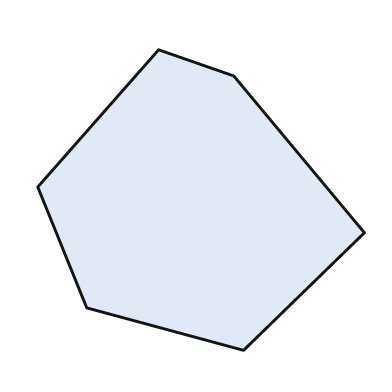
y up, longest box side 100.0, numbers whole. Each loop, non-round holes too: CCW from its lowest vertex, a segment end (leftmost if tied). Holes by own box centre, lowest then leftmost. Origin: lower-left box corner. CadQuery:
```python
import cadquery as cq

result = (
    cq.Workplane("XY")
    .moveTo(63.0, 0.0)
    .lineTo(100.0, 36.0)
    .lineTo(60.0, 84.0)
    .lineTo(37.0, 92.0)
    .lineTo(0.0, 50.0)
    .lineTo(15.0, 13.0)
    .close()
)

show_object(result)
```